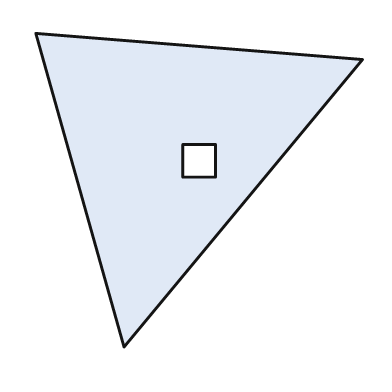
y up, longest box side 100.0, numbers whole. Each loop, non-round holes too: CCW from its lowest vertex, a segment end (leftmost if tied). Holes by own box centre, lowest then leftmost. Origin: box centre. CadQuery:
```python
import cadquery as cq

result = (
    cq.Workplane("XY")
    .moveTo(-23.0, -48.0)
    .lineTo(50.0, 40.0)
    .lineTo(-50.0, 48.0)
    .close()
    .moveTo(-5.0, 4.0)
    .lineTo(5.0, 4.0)
    .lineTo(5.0, 14.0)
    .lineTo(-5.0, 14.0)
    .close()
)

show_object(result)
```